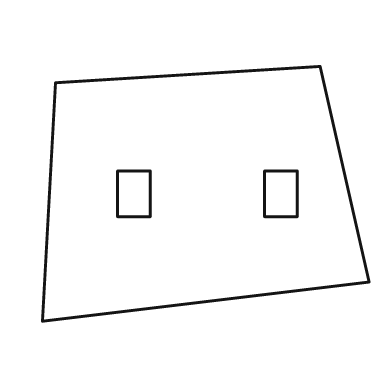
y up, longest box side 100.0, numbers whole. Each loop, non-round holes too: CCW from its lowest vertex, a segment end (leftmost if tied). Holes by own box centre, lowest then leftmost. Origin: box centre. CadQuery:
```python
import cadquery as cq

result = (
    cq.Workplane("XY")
    .moveTo(-50.0, -39.0)
    .lineTo(50.0, -27.0)
    .lineTo(35.0, 39.0)
    .lineTo(-46.0, 34.0)
    .close()
    .moveTo(-27.0, -7.0)
    .lineTo(-17.0, -7.0)
    .lineTo(-17.0, 7.0)
    .lineTo(-27.0, 7.0)
    .close()
    .moveTo(18.0, -7.0)
    .lineTo(28.0, -7.0)
    .lineTo(28.0, 7.0)
    .lineTo(18.0, 7.0)
    .close()
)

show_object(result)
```